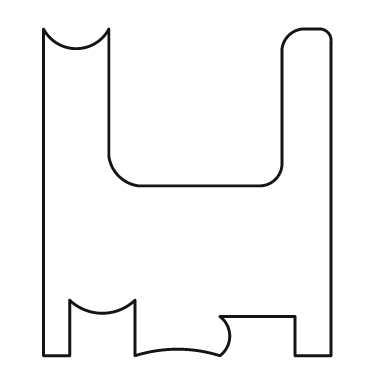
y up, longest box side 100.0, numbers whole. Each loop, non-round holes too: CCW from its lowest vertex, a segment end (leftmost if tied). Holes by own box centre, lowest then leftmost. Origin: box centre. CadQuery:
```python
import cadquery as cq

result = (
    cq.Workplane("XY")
    .moveTo(-44.0, -50.0)
    .lineTo(-36.0, -50.0)
    .lineTo(-36.0, -33.0)
    .threePointArc((-26.0, -37.0), (-16.0, -33.0))
    .lineTo(-16.0, -50.0)
    .threePointArc((-3.0, -48.0), (10.0, -50.0))
    .threePointArc((13.0, -44.0), (10.0, -38.0))
    .lineTo(33.0, -38.0)
    .lineTo(33.0, -50.0)
    .lineTo(44.0, -50.0)
    .lineTo(44.0, 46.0)
    .threePointArc((43.0, 49.0), (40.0, 50.0))
    .lineTo(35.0, 50.0)
    .threePointArc((31.0, 48.0), (29.0, 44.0))
    .lineTo(29.0, 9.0)
    .threePointArc((27.0, 4.0), (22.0, 2.0))
    .lineTo(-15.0, 2.0)
    .threePointArc((-21.0, 5.0), (-24.0, 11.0))
    .lineTo(-24.0, 50.0)
    .threePointArc((-34.0, 44.0), (-44.0, 50.0))
    .close()
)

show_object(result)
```